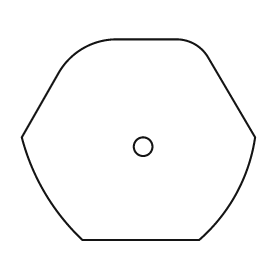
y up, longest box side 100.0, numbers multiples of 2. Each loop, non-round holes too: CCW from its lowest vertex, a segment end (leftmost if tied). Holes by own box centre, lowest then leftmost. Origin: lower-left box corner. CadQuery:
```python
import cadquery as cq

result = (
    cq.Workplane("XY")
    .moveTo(26.0, 0.0)
    .lineTo(76.0, 0.0)
    .threePointArc((92.0, 20.0), (100.0, 44.0))
    .lineTo(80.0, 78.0)
    .threePointArc((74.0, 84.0), (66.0, 86.0))
    .lineTo(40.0, 86.0)
    .threePointArc((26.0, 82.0), (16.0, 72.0))
    .lineTo(0.0, 44.0)
    .threePointArc((10.0, 20.0), (26.0, 0.0))
    .close()
    .moveTo(52.0, 40.0)
    .circle(4.0)
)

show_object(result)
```